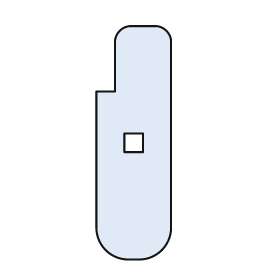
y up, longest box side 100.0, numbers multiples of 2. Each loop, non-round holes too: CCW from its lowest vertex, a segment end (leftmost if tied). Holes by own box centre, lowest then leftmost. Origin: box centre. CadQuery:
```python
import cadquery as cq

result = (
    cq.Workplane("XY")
    .moveTo(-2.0, -50.0)
    .lineTo(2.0, -50.0)
    .threePointArc((12.0, -46.0), (16.0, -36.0))
    .lineTo(16.0, 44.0)
    .threePointArc((14.0, 48.0), (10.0, 50.0))
    .lineTo(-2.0, 50.0)
    .threePointArc((-6.0, 48.0), (-8.0, 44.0))
    .lineTo(-8.0, 22.0)
    .lineTo(-16.0, 22.0)
    .lineTo(-16.0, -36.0)
    .threePointArc((-12.0, -46.0), (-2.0, -50.0))
    .close()
    .moveTo(-4.0, -4.0)
    .lineTo(4.0, -4.0)
    .lineTo(4.0, 4.0)
    .lineTo(-4.0, 4.0)
    .close()
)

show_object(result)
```